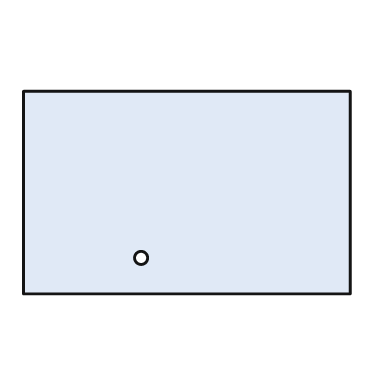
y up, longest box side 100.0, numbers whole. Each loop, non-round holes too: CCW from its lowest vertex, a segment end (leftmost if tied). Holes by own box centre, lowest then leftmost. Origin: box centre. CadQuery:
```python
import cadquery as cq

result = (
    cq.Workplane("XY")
    .moveTo(-50.0, -31.0)
    .lineTo(50.0, -31.0)
    .lineTo(50.0, 31.0)
    .lineTo(-50.0, 31.0)
    .close()
    .moveTo(-14.0, -20.0)
    .circle(2.0)
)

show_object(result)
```